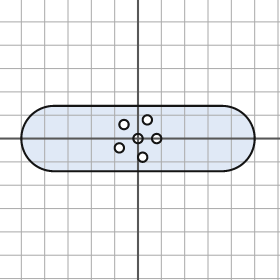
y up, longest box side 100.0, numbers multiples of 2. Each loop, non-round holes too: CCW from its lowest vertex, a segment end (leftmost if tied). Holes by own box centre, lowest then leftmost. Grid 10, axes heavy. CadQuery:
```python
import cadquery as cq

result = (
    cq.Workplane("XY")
    .moveTo(-36.0, -14.0)
    .lineTo(36.0, -14.0)
    .threePointArc((50.0, 0.0), (36.0, 14.0))
    .lineTo(-36.0, 14.0)
    .threePointArc((-50.0, 0.0), (-36.0, -14.0))
    .close()
    .moveTo(2.0, -8.0)
    .circle(2.0)
    .moveTo(-8.0, -4.0)
    .circle(2.0)
    .moveTo(0.0, 0.0)
    .circle(2.0)
    .moveTo(8.0, 0.0)
    .circle(2.0)
    .moveTo(-6.0, 6.0)
    .circle(2.0)
    .moveTo(4.0, 8.0)
    .circle(2.0)
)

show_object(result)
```